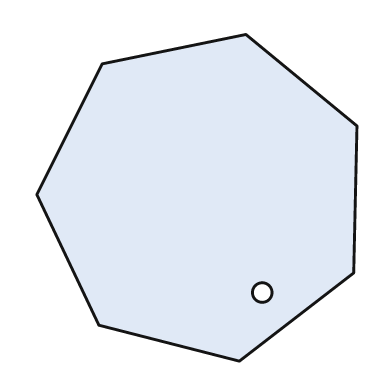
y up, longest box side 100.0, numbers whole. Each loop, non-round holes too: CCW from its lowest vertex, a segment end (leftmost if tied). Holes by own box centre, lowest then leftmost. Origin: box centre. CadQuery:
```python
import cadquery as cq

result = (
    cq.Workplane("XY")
    .moveTo(13.0, -50.0)
    .lineTo(48.0, -23.0)
    .lineTo(49.0, 22.0)
    .lineTo(15.0, 50.0)
    .lineTo(-29.0, 41.0)
    .lineTo(-49.0, 1.0)
    .lineTo(-30.0, -39.0)
    .close()
    .moveTo(20.0, -29.0)
    .circle(3.0)
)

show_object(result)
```